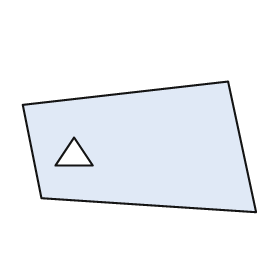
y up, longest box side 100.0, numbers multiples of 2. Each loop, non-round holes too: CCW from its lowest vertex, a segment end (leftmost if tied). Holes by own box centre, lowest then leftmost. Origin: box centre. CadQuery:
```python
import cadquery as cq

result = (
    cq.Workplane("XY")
    .moveTo(50.0, -28.0)
    .lineTo(38.0, 28.0)
    .lineTo(-50.0, 18.0)
    .lineTo(-42.0, -22.0)
    .close()
    .moveTo(-36.0, -8.0)
    .lineTo(-20.0, -8.0)
    .lineTo(-28.0, 4.0)
    .close()
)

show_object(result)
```